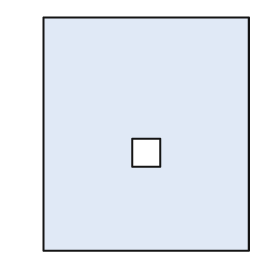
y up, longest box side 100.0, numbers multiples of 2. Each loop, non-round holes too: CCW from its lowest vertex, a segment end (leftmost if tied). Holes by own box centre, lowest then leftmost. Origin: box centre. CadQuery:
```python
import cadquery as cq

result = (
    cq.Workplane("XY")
    .moveTo(-44.0, -50.0)
    .lineTo(44.0, -50.0)
    .lineTo(44.0, 50.0)
    .lineTo(-44.0, 50.0)
    .close()
    .moveTo(-6.0, -14.0)
    .lineTo(6.0, -14.0)
    .lineTo(6.0, -2.0)
    .lineTo(-6.0, -2.0)
    .close()
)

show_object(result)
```